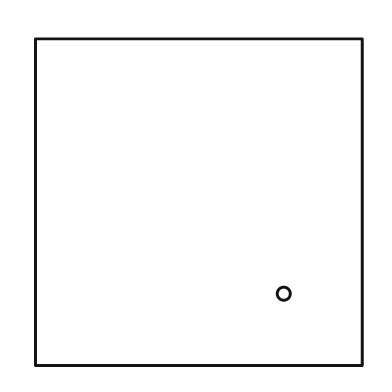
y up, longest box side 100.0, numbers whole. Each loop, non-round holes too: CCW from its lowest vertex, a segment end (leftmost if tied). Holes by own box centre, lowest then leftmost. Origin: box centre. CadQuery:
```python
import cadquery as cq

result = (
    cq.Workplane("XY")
    .moveTo(-50.0, -50.0)
    .lineTo(50.0, -50.0)
    .lineTo(50.0, 50.0)
    .lineTo(-50.0, 50.0)
    .close()
    .moveTo(26.0, -28.0)
    .circle(2.0)
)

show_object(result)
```